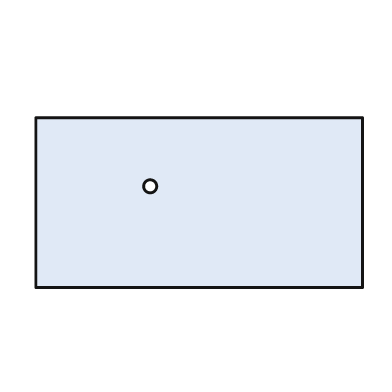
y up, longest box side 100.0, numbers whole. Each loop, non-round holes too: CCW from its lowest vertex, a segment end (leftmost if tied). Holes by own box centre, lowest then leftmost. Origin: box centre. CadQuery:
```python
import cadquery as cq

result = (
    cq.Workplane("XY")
    .moveTo(-50.0, -26.0)
    .lineTo(50.0, -26.0)
    .lineTo(50.0, 26.0)
    .lineTo(-50.0, 26.0)
    .close()
    .moveTo(-15.0, 5.0)
    .circle(2.0)
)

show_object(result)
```